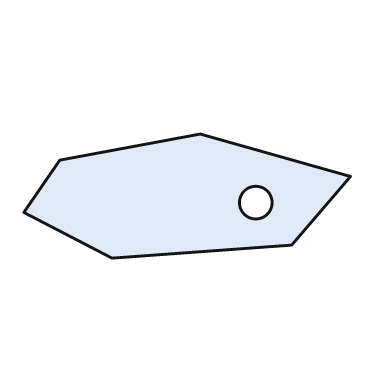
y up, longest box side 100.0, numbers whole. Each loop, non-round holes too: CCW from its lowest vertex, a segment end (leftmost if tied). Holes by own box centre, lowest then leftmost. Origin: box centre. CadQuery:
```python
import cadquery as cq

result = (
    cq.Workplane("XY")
    .moveTo(-23.0, -19.0)
    .lineTo(32.0, -15.0)
    .lineTo(50.0, 6.0)
    .lineTo(4.0, 19.0)
    .lineTo(-39.0, 11.0)
    .lineTo(-50.0, -5.0)
    .close()
    .moveTo(21.0, -2.0)
    .circle(5.0)
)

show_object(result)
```